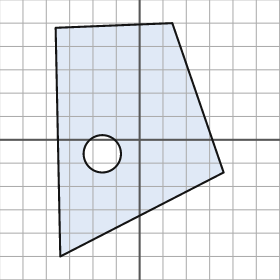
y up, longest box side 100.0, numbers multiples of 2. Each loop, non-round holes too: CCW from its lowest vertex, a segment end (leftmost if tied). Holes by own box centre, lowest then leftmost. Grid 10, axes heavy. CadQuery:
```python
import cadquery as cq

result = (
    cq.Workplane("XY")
    .moveTo(-34.0, -50.0)
    .lineTo(36.0, -14.0)
    .lineTo(14.0, 50.0)
    .lineTo(-36.0, 48.0)
    .close()
    .moveTo(-16.0, -6.0)
    .circle(8.0)
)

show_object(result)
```